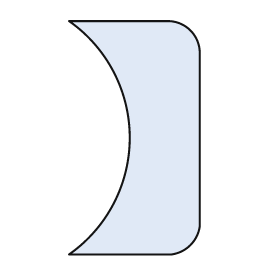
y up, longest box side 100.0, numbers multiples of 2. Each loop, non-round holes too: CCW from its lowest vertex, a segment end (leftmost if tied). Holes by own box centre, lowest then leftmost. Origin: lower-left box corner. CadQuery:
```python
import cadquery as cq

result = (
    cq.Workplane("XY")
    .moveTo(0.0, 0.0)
    .lineTo(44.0, 0.0)
    .threePointArc((52.0, 4.0), (56.0, 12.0))
    .lineTo(56.0, 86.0)
    .threePointArc((52.0, 96.0), (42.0, 100.0))
    .lineTo(0.0, 100.0)
    .threePointArc((26.0, 50.0), (0.0, 0.0))
    .close()
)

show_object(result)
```